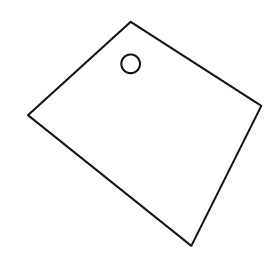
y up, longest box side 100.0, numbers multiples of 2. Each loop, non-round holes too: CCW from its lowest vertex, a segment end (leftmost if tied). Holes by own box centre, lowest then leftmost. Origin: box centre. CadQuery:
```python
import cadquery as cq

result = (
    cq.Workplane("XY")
    .moveTo(20.0, -48.0)
    .lineTo(50.0, 12.0)
    .lineTo(-6.0, 48.0)
    .lineTo(-50.0, 8.0)
    .close()
    .moveTo(-6.0, 30.0)
    .circle(4.0)
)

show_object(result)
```